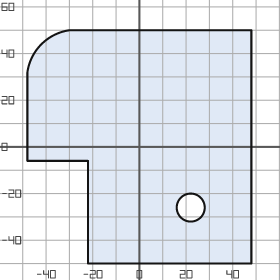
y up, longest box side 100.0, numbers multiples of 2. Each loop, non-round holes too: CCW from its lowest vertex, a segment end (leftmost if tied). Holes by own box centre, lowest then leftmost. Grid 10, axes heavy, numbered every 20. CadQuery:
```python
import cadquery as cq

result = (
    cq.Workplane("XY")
    .moveTo(-22.0, -50.0)
    .lineTo(48.0, -50.0)
    .lineTo(48.0, 50.0)
    .lineTo(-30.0, 50.0)
    .threePointArc((-42.0, 44.0), (-48.0, 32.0))
    .lineTo(-48.0, -6.0)
    .lineTo(-22.0, -6.0)
    .close()
    .moveTo(22.0, -26.0)
    .circle(6.0)
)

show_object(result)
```